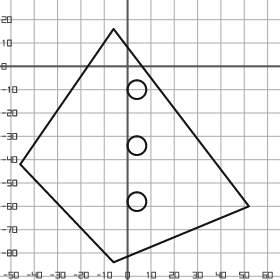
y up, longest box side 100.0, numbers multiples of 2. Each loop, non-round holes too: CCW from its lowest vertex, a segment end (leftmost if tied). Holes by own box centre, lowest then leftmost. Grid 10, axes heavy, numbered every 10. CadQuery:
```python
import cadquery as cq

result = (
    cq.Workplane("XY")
    .moveTo(-6.0, -84.0)
    .lineTo(52.0, -60.0)
    .lineTo(-6.0, 16.0)
    .lineTo(-46.0, -42.0)
    .close()
    .moveTo(4.0, -58.0)
    .circle(4.0)
    .moveTo(4.0, -34.0)
    .circle(4.0)
    .moveTo(4.0, -10.0)
    .circle(4.0)
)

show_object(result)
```